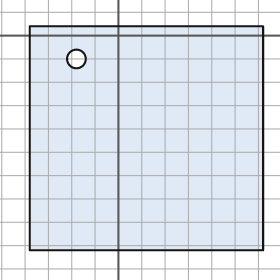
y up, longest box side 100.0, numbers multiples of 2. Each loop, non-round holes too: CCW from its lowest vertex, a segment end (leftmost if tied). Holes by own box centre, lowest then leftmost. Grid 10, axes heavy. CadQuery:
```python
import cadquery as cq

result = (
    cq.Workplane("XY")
    .moveTo(-38.0, -92.0)
    .lineTo(62.0, -92.0)
    .lineTo(62.0, 4.0)
    .lineTo(-38.0, 4.0)
    .close()
    .moveTo(-18.0, -10.0)
    .circle(4.0)
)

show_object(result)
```